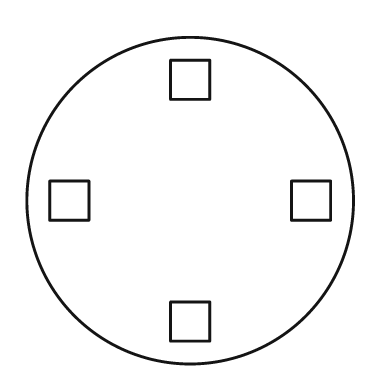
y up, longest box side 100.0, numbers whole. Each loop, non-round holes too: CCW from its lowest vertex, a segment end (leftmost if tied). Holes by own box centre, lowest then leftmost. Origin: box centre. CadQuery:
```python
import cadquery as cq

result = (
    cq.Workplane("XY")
    .moveTo(0.0, 0.0)
    .circle(50.0)
    .moveTo(-6.0, -43.0)
    .lineTo(6.0, -43.0)
    .lineTo(6.0, -31.0)
    .lineTo(-6.0, -31.0)
    .close()
    .moveTo(-43.0, -6.0)
    .lineTo(-31.0, -6.0)
    .lineTo(-31.0, 6.0)
    .lineTo(-43.0, 6.0)
    .close()
    .moveTo(31.0, -6.0)
    .lineTo(43.0, -6.0)
    .lineTo(43.0, 6.0)
    .lineTo(31.0, 6.0)
    .close()
    .moveTo(-6.0, 31.0)
    .lineTo(6.0, 31.0)
    .lineTo(6.0, 43.0)
    .lineTo(-6.0, 43.0)
    .close()
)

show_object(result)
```